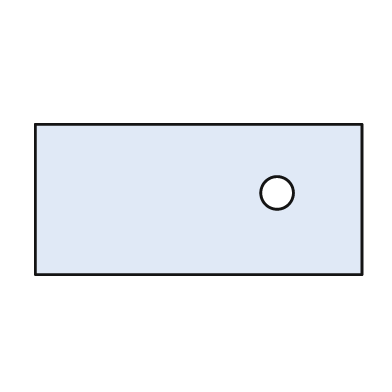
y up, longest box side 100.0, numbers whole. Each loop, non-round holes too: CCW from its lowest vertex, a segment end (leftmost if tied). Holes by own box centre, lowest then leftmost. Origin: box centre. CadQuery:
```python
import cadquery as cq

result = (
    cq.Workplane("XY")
    .moveTo(-50.0, -23.0)
    .lineTo(50.0, -23.0)
    .lineTo(50.0, 23.0)
    .lineTo(-50.0, 23.0)
    .close()
    .moveTo(24.0, 2.0)
    .circle(5.0)
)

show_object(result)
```